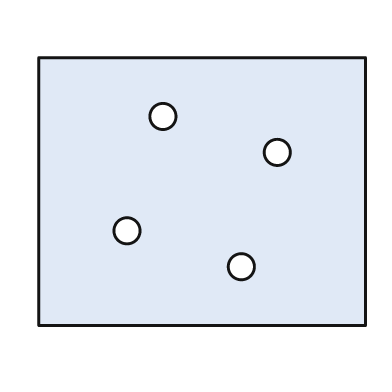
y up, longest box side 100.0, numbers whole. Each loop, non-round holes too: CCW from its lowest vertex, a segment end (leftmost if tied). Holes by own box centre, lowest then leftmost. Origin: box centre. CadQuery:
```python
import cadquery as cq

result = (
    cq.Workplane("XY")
    .moveTo(-50.0, -41.0)
    .lineTo(50.0, -41.0)
    .lineTo(50.0, 41.0)
    .lineTo(-50.0, 41.0)
    .close()
    .moveTo(12.0, -23.0)
    .circle(4.0)
    .moveTo(-23.0, -12.0)
    .circle(4.0)
    .moveTo(23.0, 12.0)
    .circle(4.0)
    .moveTo(-12.0, 23.0)
    .circle(4.0)
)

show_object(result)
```